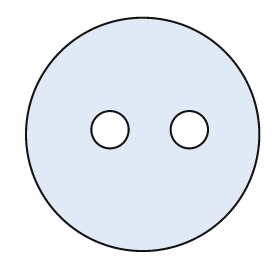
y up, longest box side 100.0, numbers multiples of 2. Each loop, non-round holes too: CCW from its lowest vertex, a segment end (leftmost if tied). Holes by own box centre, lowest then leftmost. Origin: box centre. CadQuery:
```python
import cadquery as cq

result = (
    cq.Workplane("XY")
    .moveTo(0.0, 0.0)
    .circle(50.0)
    .moveTo(-14.0, 2.0)
    .circle(8.0)
    .moveTo(20.0, 2.0)
    .circle(8.0)
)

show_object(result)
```